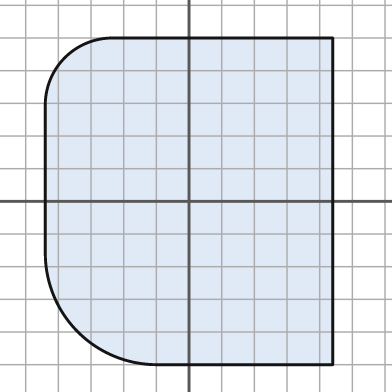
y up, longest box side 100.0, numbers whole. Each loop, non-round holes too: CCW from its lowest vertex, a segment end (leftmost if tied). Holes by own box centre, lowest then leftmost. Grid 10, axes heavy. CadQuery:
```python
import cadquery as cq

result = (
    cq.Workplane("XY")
    .moveTo(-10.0, -50.0)
    .lineTo(44.0, -50.0)
    .lineTo(44.0, 50.0)
    .lineTo(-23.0, 50.0)
    .threePointArc((-38.0, 44.0), (-44.0, 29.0))
    .lineTo(-44.0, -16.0)
    .threePointArc((-34.0, -40.0), (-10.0, -50.0))
    .close()
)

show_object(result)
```